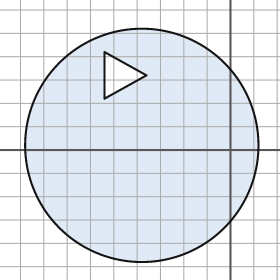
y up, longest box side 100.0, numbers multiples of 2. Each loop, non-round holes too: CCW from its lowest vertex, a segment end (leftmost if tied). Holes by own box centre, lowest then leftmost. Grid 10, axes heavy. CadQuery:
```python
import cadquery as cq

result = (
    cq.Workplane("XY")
    .moveTo(-38.0, 2.0)
    .circle(50.0)
    .moveTo(-54.0, 22.0)
    .lineTo(-36.0, 32.0)
    .lineTo(-54.0, 42.0)
    .close()
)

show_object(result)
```